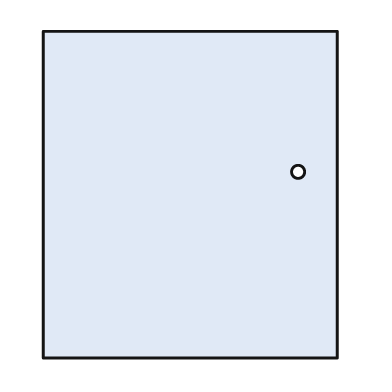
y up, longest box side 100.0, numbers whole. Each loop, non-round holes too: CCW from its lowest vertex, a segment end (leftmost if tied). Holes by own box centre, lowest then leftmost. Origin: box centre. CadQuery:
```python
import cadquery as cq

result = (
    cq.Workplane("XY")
    .moveTo(-45.0, -50.0)
    .lineTo(45.0, -50.0)
    .lineTo(45.0, 50.0)
    .lineTo(-45.0, 50.0)
    .close()
    .moveTo(33.0, 7.0)
    .circle(2.0)
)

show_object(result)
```